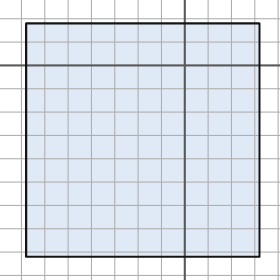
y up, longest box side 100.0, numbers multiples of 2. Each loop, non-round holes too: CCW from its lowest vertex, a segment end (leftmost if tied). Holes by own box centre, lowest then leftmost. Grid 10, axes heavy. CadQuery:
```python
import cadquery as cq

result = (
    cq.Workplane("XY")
    .moveTo(-68.0, -82.0)
    .lineTo(32.0, -82.0)
    .lineTo(32.0, 18.0)
    .lineTo(-68.0, 18.0)
    .close()
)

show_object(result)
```